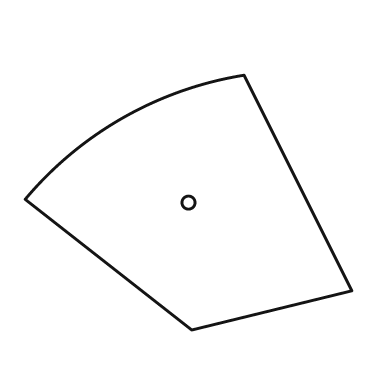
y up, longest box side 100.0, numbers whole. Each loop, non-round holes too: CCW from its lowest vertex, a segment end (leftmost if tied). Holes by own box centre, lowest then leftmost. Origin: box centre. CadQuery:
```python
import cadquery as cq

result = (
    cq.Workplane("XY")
    .moveTo(1.0, -39.0)
    .lineTo(50.0, -27.0)
    .lineTo(17.0, 39.0)
    .threePointArc((-20.0, 26.0), (-50.0, 1.0))
    .close()
    .moveTo(0.0, 0.0)
    .circle(2.0)
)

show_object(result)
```